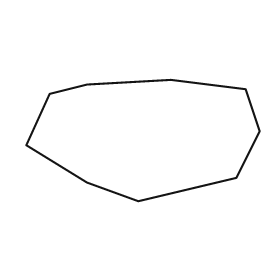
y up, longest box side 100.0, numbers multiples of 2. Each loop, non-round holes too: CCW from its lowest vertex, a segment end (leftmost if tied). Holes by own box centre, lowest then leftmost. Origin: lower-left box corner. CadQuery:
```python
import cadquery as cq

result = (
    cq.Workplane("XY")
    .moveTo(48.0, 0.0)
    .lineTo(90.0, 10.0)
    .lineTo(100.0, 30.0)
    .lineTo(94.0, 48.0)
    .lineTo(62.0, 52.0)
    .lineTo(26.0, 50.0)
    .lineTo(10.0, 46.0)
    .lineTo(0.0, 24.0)
    .lineTo(26.0, 8.0)
    .close()
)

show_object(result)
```